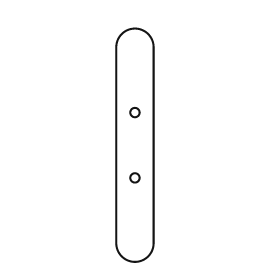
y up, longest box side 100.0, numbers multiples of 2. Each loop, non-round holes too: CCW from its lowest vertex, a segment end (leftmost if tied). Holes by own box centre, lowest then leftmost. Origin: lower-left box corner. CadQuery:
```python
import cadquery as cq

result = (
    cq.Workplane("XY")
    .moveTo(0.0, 8.0)
    .threePointArc((8.0, 0.0), (16.0, 8.0))
    .lineTo(16.0, 92.0)
    .threePointArc((8.0, 100.0), (0.0, 92.0))
    .close()
    .moveTo(8.0, 36.0)
    .circle(2.0)
    .moveTo(8.0, 64.0)
    .circle(2.0)
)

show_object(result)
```